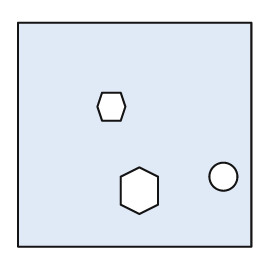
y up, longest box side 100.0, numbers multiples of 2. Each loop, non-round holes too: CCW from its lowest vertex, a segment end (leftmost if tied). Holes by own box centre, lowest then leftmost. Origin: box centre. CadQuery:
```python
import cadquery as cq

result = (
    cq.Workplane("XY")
    .moveTo(-50.0, -48.0)
    .lineTo(50.0, -48.0)
    .lineTo(50.0, 48.0)
    .lineTo(-50.0, 48.0)
    .close()
    .moveTo(2.0, -34.0)
    .lineTo(10.0, -30.0)
    .lineTo(10.0, -18.0)
    .lineTo(2.0, -14.0)
    .lineTo(-6.0, -18.0)
    .lineTo(-6.0, -30.0)
    .close()
    .moveTo(38.0, -18.0)
    .circle(6.0)
    .moveTo(-14.0, 6.0)
    .lineTo(-6.0, 6.0)
    .lineTo(-4.0, 12.0)
    .lineTo(-6.0, 18.0)
    .lineTo(-14.0, 18.0)
    .lineTo(-16.0, 12.0)
    .close()
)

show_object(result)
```